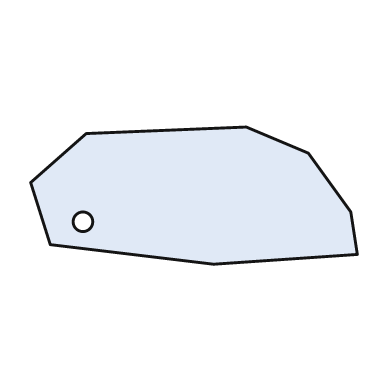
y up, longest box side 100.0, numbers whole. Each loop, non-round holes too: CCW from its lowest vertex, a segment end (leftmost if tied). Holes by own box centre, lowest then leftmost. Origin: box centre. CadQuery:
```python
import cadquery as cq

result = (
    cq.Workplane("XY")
    .moveTo(6.0, -21.0)
    .lineTo(50.0, -18.0)
    .lineTo(48.0, -5.0)
    .lineTo(35.0, 13.0)
    .lineTo(16.0, 21.0)
    .lineTo(-33.0, 19.0)
    .lineTo(-50.0, 4.0)
    .lineTo(-44.0, -15.0)
    .close()
    .moveTo(-34.0, -8.0)
    .circle(3.0)
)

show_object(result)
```